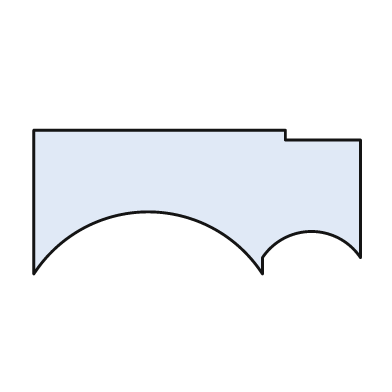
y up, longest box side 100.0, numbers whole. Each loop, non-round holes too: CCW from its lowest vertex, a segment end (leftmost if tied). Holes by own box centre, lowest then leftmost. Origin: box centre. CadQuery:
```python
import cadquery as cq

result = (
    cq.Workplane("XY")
    .moveTo(-50.0, -22.0)
    .threePointArc((-15.0, -3.0), (20.0, -22.0))
    .lineTo(20.0, -17.0)
    .threePointArc((35.0, -9.0), (50.0, -17.0))
    .lineTo(50.0, 19.0)
    .lineTo(27.0, 19.0)
    .lineTo(27.0, 22.0)
    .lineTo(-50.0, 22.0)
    .close()
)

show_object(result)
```